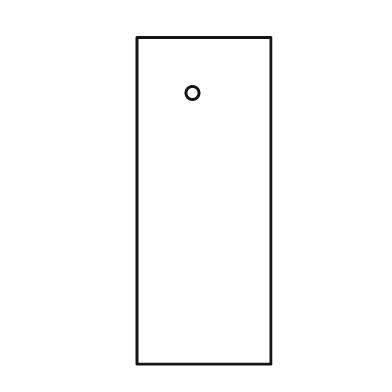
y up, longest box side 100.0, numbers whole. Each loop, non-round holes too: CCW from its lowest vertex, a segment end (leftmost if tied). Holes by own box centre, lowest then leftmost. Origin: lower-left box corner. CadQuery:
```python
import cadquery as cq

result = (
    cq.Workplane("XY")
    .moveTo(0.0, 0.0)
    .lineTo(41.0, 0.0)
    .lineTo(41.0, 100.0)
    .lineTo(0.0, 100.0)
    .close()
    .moveTo(17.0, 83.0)
    .circle(2.0)
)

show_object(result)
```